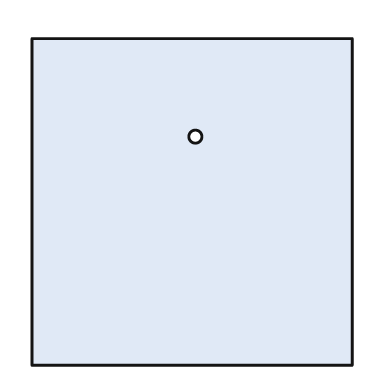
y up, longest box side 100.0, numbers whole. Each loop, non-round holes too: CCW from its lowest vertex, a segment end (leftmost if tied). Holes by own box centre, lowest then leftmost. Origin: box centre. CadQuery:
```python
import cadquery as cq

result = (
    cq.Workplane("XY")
    .moveTo(-49.0, -50.0)
    .lineTo(49.0, -50.0)
    .lineTo(49.0, 50.0)
    .lineTo(-49.0, 50.0)
    .close()
    .moveTo(1.0, 20.0)
    .circle(2.0)
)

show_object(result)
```